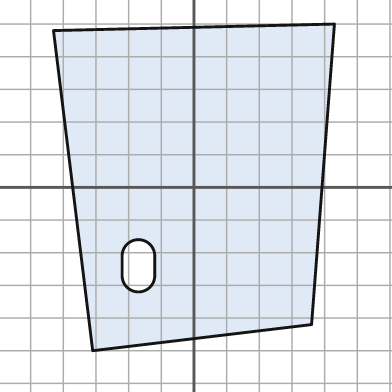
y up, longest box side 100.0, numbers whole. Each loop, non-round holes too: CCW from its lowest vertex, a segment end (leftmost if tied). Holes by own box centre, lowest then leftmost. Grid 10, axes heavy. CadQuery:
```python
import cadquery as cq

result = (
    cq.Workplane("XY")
    .moveTo(-31.0, -50.0)
    .lineTo(36.0, -42.0)
    .lineTo(43.0, 50.0)
    .lineTo(-43.0, 48.0)
    .close()
    .moveTo(-22.0, -27.0)
    .threePointArc((-17.0, -32.0), (-12.0, -27.0))
    .lineTo(-12.0, -21.0)
    .threePointArc((-17.0, -16.0), (-22.0, -21.0))
    .close()
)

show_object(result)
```